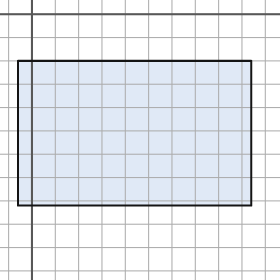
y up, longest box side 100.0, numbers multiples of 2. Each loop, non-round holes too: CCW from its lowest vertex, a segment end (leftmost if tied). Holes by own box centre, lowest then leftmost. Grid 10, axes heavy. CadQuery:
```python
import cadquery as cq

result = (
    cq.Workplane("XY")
    .moveTo(-6.0, -82.0)
    .lineTo(94.0, -82.0)
    .lineTo(94.0, -20.0)
    .lineTo(-6.0, -20.0)
    .close()
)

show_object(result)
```